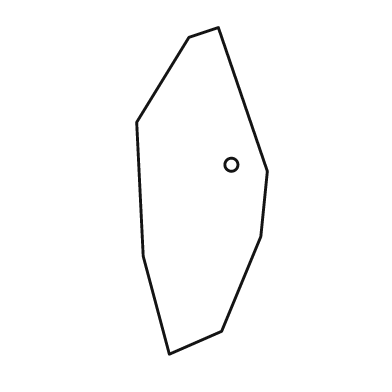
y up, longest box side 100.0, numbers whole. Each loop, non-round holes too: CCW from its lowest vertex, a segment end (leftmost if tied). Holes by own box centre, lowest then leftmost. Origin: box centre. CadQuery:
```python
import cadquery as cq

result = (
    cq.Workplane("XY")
    .moveTo(-10.0, -50.0)
    .lineTo(6.0, -43.0)
    .lineTo(18.0, -14.0)
    .lineTo(20.0, 6.0)
    .lineTo(5.0, 50.0)
    .lineTo(-4.0, 47.0)
    .lineTo(-20.0, 21.0)
    .lineTo(-18.0, -20.0)
    .close()
    .moveTo(9.0, 8.0)
    .circle(2.0)
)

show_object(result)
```